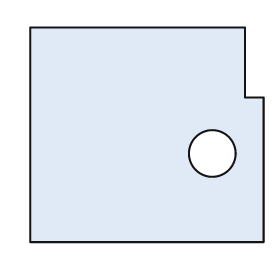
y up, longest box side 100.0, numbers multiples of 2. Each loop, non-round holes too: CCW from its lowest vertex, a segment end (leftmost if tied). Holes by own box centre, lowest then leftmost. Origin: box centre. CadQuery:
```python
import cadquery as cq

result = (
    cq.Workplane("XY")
    .moveTo(-50.0, -46.0)
    .lineTo(50.0, -46.0)
    .lineTo(50.0, 16.0)
    .lineTo(42.0, 16.0)
    .lineTo(42.0, 46.0)
    .lineTo(-50.0, 46.0)
    .close()
    .moveTo(28.0, -8.0)
    .circle(10.0)
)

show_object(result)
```